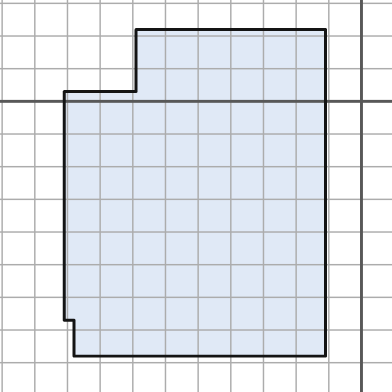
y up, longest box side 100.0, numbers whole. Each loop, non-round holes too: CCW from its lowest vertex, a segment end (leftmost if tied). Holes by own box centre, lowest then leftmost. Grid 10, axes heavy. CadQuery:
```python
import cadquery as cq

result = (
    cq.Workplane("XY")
    .moveTo(-88.0, -78.0)
    .lineTo(-11.0, -78.0)
    .lineTo(-11.0, 22.0)
    .lineTo(-69.0, 22.0)
    .lineTo(-69.0, 3.0)
    .lineTo(-91.0, 3.0)
    .lineTo(-91.0, -67.0)
    .lineTo(-88.0, -67.0)
    .close()
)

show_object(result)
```